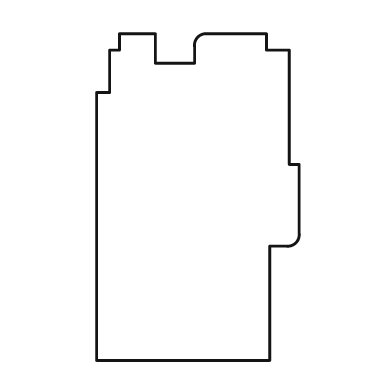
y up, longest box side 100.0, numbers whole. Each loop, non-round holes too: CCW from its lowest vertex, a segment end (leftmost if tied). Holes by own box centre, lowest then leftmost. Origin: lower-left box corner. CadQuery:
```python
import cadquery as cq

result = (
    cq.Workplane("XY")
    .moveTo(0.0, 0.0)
    .lineTo(53.0, 0.0)
    .lineTo(53.0, 35.0)
    .lineTo(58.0, 35.0)
    .threePointArc((61.0, 36.0), (62.0, 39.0))
    .lineTo(62.0, 60.0)
    .lineTo(59.0, 60.0)
    .lineTo(59.0, 95.0)
    .lineTo(52.0, 95.0)
    .lineTo(52.0, 100.0)
    .lineTo(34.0, 100.0)
    .threePointArc((31.0, 99.0), (30.0, 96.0))
    .lineTo(30.0, 91.0)
    .lineTo(18.0, 91.0)
    .lineTo(18.0, 100.0)
    .lineTo(7.0, 100.0)
    .lineTo(7.0, 95.0)
    .lineTo(4.0, 95.0)
    .lineTo(4.0, 82.0)
    .lineTo(0.0, 82.0)
    .close()
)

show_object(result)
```